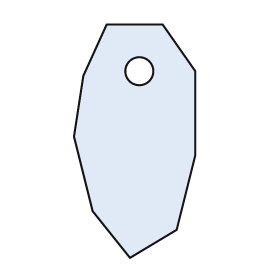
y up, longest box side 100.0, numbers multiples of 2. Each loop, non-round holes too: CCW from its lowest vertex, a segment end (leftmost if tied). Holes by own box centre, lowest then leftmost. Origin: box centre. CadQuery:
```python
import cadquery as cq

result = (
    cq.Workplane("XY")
    .moveTo(-2.0, -50.0)
    .lineTo(18.0, -38.0)
    .lineTo(26.0, -6.0)
    .lineTo(26.0, 30.0)
    .lineTo(12.0, 50.0)
    .lineTo(-12.0, 50.0)
    .lineTo(-22.0, 28.0)
    .lineTo(-26.0, 2.0)
    .lineTo(-18.0, -30.0)
    .close()
    .moveTo(2.0, 30.0)
    .circle(6.0)
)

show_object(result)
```